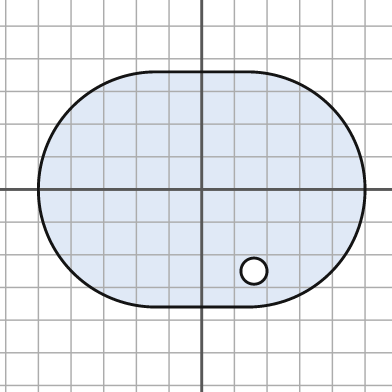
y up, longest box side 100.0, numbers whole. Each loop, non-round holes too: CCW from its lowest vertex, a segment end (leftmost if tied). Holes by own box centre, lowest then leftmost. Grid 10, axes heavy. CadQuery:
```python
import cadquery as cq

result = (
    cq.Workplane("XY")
    .moveTo(-14.0, -36.0)
    .lineTo(14.0, -36.0)
    .threePointArc((50.0, 0.0), (14.0, 36.0))
    .lineTo(-14.0, 36.0)
    .threePointArc((-50.0, 0.0), (-14.0, -36.0))
    .close()
    .moveTo(16.0, -25.0)
    .circle(4.0)
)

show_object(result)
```